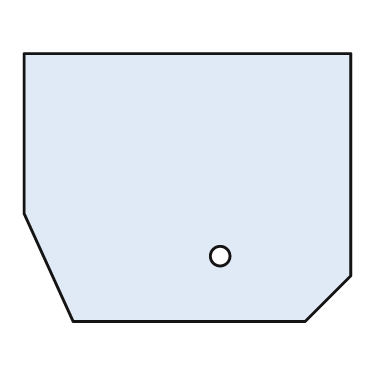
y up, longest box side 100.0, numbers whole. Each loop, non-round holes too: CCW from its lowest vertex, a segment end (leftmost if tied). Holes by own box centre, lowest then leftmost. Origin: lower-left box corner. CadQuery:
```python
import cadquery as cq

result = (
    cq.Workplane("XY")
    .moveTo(15.0, 0.0)
    .lineTo(86.0, 0.0)
    .lineTo(100.0, 14.0)
    .lineTo(100.0, 82.0)
    .lineTo(0.0, 82.0)
    .lineTo(0.0, 33.0)
    .close()
    .moveTo(60.0, 20.0)
    .circle(3.0)
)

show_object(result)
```